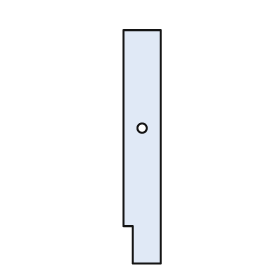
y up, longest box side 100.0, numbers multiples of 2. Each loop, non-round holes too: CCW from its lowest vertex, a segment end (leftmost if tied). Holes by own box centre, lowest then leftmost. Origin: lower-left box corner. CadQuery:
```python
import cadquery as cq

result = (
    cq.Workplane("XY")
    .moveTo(4.0, 0.0)
    .lineTo(16.0, 0.0)
    .lineTo(16.0, 100.0)
    .lineTo(0.0, 100.0)
    .lineTo(0.0, 16.0)
    .lineTo(4.0, 16.0)
    .close()
    .moveTo(8.0, 58.0)
    .circle(2.0)
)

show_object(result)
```